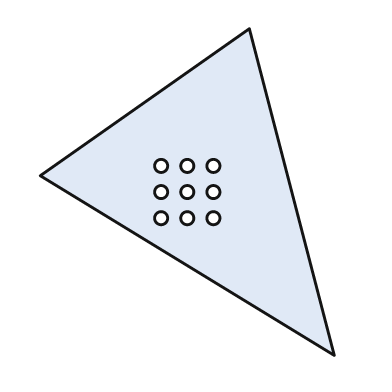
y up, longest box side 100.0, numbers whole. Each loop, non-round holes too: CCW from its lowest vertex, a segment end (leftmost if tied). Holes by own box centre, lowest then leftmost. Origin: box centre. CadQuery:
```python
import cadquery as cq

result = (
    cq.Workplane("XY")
    .moveTo(45.0, -50.0)
    .lineTo(19.0, 50.0)
    .lineTo(-45.0, 5.0)
    .close()
    .moveTo(-8.0, -8.0)
    .circle(2.0)
    .moveTo(0.0, -8.0)
    .circle(2.0)
    .moveTo(8.0, -8.0)
    .circle(2.0)
    .moveTo(-8.0, 0.0)
    .circle(2.0)
    .moveTo(0.0, 0.0)
    .circle(2.0)
    .moveTo(8.0, 0.0)
    .circle(2.0)
    .moveTo(-8.0, 8.0)
    .circle(2.0)
    .moveTo(0.0, 8.0)
    .circle(2.0)
    .moveTo(8.0, 8.0)
    .circle(2.0)
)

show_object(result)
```